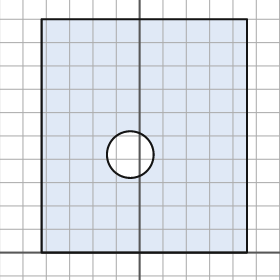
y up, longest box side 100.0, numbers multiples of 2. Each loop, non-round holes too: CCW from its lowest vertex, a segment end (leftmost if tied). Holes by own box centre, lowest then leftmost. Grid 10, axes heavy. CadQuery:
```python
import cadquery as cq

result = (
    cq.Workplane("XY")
    .moveTo(-42.0, 0.0)
    .lineTo(46.0, 0.0)
    .lineTo(46.0, 100.0)
    .lineTo(-42.0, 100.0)
    .close()
    .moveTo(-4.0, 42.0)
    .circle(10.0)
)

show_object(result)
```